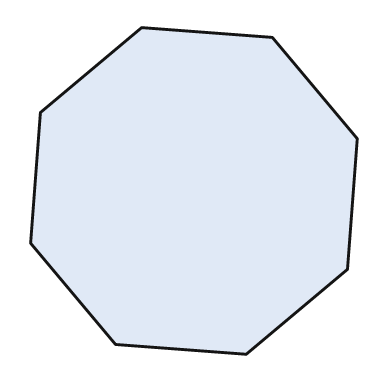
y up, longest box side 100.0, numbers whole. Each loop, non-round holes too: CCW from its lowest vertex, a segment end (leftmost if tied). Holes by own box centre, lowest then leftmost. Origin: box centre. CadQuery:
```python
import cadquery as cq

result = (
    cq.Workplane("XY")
    .moveTo(16.0, -50.0)
    .lineTo(47.0, -24.0)
    .lineTo(50.0, 16.0)
    .lineTo(24.0, 47.0)
    .lineTo(-16.0, 50.0)
    .lineTo(-47.0, 24.0)
    .lineTo(-50.0, -16.0)
    .lineTo(-24.0, -47.0)
    .close()
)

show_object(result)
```